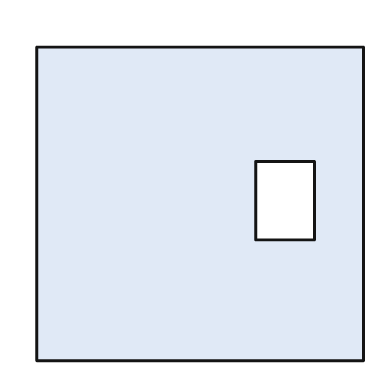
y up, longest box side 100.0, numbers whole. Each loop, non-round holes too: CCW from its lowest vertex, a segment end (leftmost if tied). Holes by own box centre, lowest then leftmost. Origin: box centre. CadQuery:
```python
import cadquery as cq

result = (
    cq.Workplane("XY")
    .moveTo(-50.0, -48.0)
    .lineTo(50.0, -48.0)
    .lineTo(50.0, 48.0)
    .lineTo(-50.0, 48.0)
    .close()
    .moveTo(17.0, -11.0)
    .lineTo(35.0, -11.0)
    .lineTo(35.0, 13.0)
    .lineTo(17.0, 13.0)
    .close()
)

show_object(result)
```